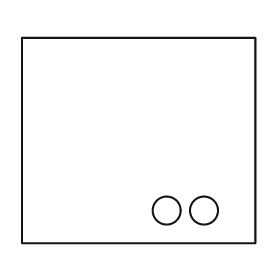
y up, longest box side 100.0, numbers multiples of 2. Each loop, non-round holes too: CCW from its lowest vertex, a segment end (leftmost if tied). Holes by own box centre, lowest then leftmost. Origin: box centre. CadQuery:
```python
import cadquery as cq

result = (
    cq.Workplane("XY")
    .moveTo(-50.0, -44.0)
    .lineTo(50.0, -44.0)
    .lineTo(50.0, 44.0)
    .lineTo(-50.0, 44.0)
    .close()
    .moveTo(12.0, -30.0)
    .circle(6.0)
    .moveTo(28.0, -30.0)
    .circle(6.0)
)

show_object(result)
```